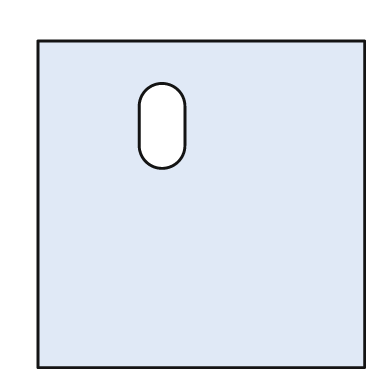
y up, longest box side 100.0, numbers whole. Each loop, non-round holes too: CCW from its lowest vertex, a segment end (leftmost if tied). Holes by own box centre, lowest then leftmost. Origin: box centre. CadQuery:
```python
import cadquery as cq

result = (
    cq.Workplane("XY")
    .moveTo(-50.0, -50.0)
    .lineTo(50.0, -50.0)
    .lineTo(50.0, 50.0)
    .lineTo(-50.0, 50.0)
    .close()
    .moveTo(-19.0, 18.0)
    .threePointArc((-12.0, 11.0), (-5.0, 18.0))
    .lineTo(-5.0, 30.0)
    .threePointArc((-12.0, 37.0), (-19.0, 30.0))
    .close()
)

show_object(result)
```